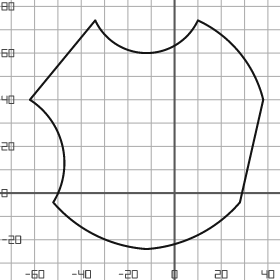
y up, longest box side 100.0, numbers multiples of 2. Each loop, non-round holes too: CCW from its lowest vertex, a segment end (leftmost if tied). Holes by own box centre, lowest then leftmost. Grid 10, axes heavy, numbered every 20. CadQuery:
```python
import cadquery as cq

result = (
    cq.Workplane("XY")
    .moveTo(-12.0, -24.0)
    .threePointArc((10.0, -18.0), (28.0, -4.0))
    .lineTo(38.0, 40.0)
    .threePointArc((28.0, 60.0), (10.0, 74.0))
    .threePointArc((-12.0, 60.0), (-34.0, 74.0))
    .lineTo(-62.0, 40.0)
    .threePointArc((-48.0, 20.0), (-52.0, -4.0))
    .threePointArc((-34.0, -18.0), (-12.0, -24.0))
    .close()
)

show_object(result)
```